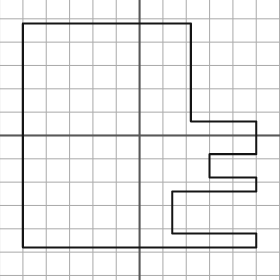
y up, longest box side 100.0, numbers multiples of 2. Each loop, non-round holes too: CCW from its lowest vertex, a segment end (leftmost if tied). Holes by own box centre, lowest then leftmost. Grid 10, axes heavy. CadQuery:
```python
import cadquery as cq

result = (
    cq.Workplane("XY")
    .moveTo(-50.0, -48.0)
    .lineTo(50.0, -48.0)
    .lineTo(50.0, -42.0)
    .lineTo(14.0, -42.0)
    .lineTo(14.0, -24.0)
    .lineTo(50.0, -24.0)
    .lineTo(50.0, -18.0)
    .lineTo(30.0, -18.0)
    .lineTo(30.0, -8.0)
    .lineTo(50.0, -8.0)
    .lineTo(50.0, 6.0)
    .lineTo(22.0, 6.0)
    .lineTo(22.0, 48.0)
    .lineTo(-50.0, 48.0)
    .close()
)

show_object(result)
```